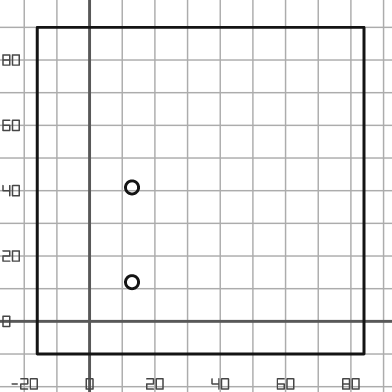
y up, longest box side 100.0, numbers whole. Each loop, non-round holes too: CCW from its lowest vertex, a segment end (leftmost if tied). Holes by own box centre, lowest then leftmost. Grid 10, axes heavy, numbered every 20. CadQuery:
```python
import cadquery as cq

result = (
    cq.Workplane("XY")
    .moveTo(-16.0, -10.0)
    .lineTo(84.0, -10.0)
    .lineTo(84.0, 90.0)
    .lineTo(-16.0, 90.0)
    .close()
    .moveTo(13.0, 12.0)
    .circle(2.0)
    .moveTo(13.0, 41.0)
    .circle(2.0)
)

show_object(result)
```